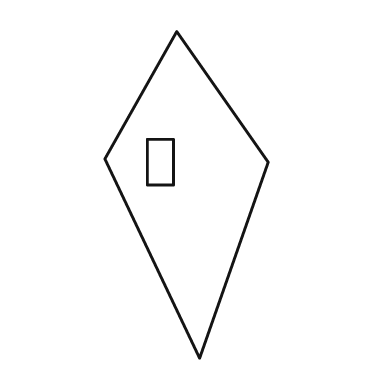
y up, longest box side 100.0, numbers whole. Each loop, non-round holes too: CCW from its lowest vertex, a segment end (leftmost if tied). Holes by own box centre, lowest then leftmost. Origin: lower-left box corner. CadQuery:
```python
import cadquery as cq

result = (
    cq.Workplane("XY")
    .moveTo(29.0, 0.0)
    .lineTo(50.0, 60.0)
    .lineTo(22.0, 100.0)
    .lineTo(0.0, 61.0)
    .close()
    .moveTo(13.0, 53.0)
    .lineTo(21.0, 53.0)
    .lineTo(21.0, 67.0)
    .lineTo(13.0, 67.0)
    .close()
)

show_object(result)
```